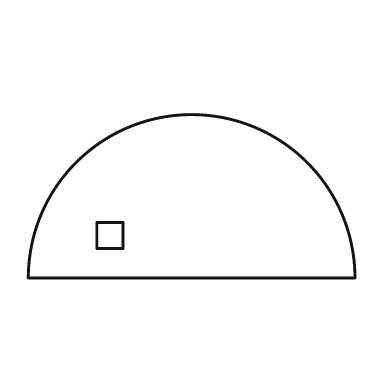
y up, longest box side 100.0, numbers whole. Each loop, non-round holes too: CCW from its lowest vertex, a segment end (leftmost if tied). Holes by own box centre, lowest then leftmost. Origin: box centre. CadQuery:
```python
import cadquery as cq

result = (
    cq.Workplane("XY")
    .moveTo(-50.0, -25.0)
    .lineTo(50.0, -25.0)
    .threePointArc((0.0, 25.0), (-50.0, -25.0))
    .close()
    .moveTo(-29.0, -16.0)
    .lineTo(-21.0, -16.0)
    .lineTo(-21.0, -8.0)
    .lineTo(-29.0, -8.0)
    .close()
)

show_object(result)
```